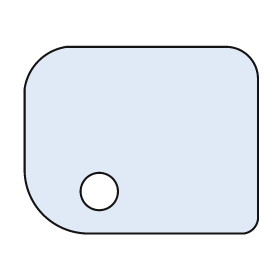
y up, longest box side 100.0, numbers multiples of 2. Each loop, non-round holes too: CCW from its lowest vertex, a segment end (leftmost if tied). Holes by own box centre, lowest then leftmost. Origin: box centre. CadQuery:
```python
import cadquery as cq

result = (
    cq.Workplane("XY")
    .moveTo(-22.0, -40.0)
    .lineTo(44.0, -40.0)
    .threePointArc((48.0, -38.0), (50.0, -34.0))
    .lineTo(50.0, 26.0)
    .threePointArc((46.0, 36.0), (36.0, 40.0))
    .lineTo(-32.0, 40.0)
    .threePointArc((-44.0, 34.0), (-50.0, 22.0))
    .lineTo(-50.0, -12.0)
    .threePointArc((-42.0, -32.0), (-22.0, -40.0))
    .close()
    .moveTo(-18.0, -22.0)
    .circle(8.0)
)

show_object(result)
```